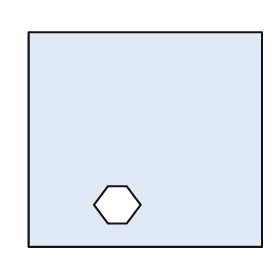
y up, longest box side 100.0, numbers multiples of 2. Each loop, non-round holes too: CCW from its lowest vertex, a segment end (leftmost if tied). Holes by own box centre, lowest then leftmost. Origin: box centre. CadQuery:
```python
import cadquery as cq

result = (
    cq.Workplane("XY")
    .moveTo(-50.0, -46.0)
    .lineTo(50.0, -46.0)
    .lineTo(50.0, 46.0)
    .lineTo(-50.0, 46.0)
    .close()
    .moveTo(-16.0, -36.0)
    .lineTo(-8.0, -36.0)
    .lineTo(-2.0, -28.0)
    .lineTo(-8.0, -20.0)
    .lineTo(-16.0, -20.0)
    .lineTo(-22.0, -28.0)
    .close()
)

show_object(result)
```